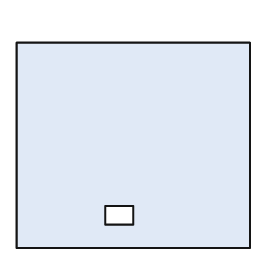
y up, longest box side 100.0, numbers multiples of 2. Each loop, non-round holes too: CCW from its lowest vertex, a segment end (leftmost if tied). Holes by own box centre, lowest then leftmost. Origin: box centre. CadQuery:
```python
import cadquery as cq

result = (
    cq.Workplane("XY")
    .moveTo(-50.0, -44.0)
    .lineTo(50.0, -44.0)
    .lineTo(50.0, 44.0)
    .lineTo(-50.0, 44.0)
    .close()
    .moveTo(-12.0, -34.0)
    .lineTo(0.0, -34.0)
    .lineTo(0.0, -26.0)
    .lineTo(-12.0, -26.0)
    .close()
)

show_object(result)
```